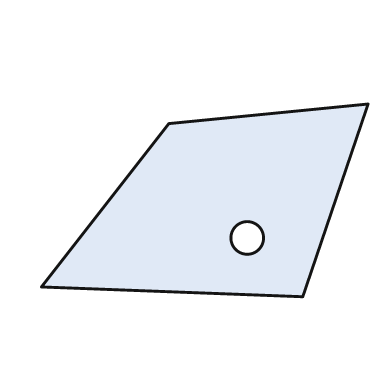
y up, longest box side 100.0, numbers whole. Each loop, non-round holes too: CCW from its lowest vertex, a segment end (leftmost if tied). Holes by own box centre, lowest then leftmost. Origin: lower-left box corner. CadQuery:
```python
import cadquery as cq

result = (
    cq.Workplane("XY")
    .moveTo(80.0, 0.0)
    .lineTo(100.0, 59.0)
    .lineTo(39.0, 53.0)
    .lineTo(0.0, 3.0)
    .close()
    .moveTo(63.0, 18.0)
    .circle(5.0)
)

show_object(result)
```